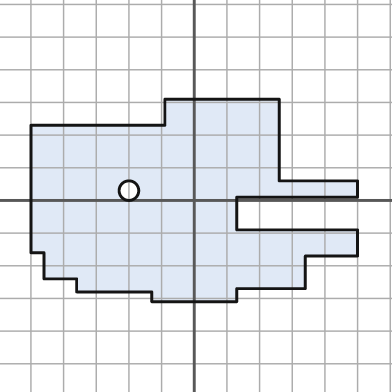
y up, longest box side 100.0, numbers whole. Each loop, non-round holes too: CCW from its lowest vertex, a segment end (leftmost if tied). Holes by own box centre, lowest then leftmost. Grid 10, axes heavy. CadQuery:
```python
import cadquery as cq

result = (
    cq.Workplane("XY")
    .moveTo(-13.0, -31.0)
    .lineTo(13.0, -31.0)
    .lineTo(13.0, -27.0)
    .lineTo(34.0, -27.0)
    .lineTo(34.0, -17.0)
    .lineTo(50.0, -17.0)
    .lineTo(50.0, -9.0)
    .lineTo(13.0, -9.0)
    .lineTo(13.0, 1.0)
    .lineTo(50.0, 1.0)
    .lineTo(50.0, 6.0)
    .lineTo(26.0, 6.0)
    .lineTo(26.0, 31.0)
    .lineTo(-9.0, 31.0)
    .lineTo(-9.0, 23.0)
    .lineTo(-50.0, 23.0)
    .lineTo(-50.0, -16.0)
    .lineTo(-46.0, -16.0)
    .lineTo(-46.0, -24.0)
    .lineTo(-36.0, -24.0)
    .lineTo(-36.0, -28.0)
    .lineTo(-13.0, -28.0)
    .close()
    .moveTo(-20.0, 3.0)
    .circle(3.0)
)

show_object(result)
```